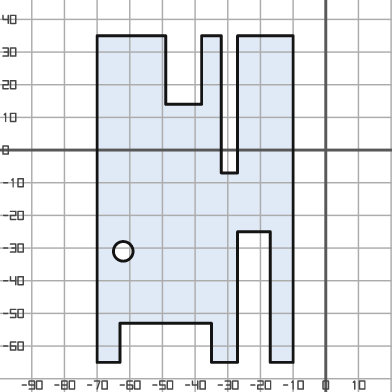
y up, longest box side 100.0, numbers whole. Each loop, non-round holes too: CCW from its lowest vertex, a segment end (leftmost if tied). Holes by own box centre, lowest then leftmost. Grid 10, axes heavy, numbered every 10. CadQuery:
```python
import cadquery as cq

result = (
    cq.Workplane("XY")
    .moveTo(-70.0, -65.0)
    .lineTo(-63.0, -65.0)
    .lineTo(-63.0, -53.0)
    .lineTo(-35.0, -53.0)
    .lineTo(-35.0, -65.0)
    .lineTo(-27.0, -65.0)
    .lineTo(-27.0, -25.0)
    .lineTo(-17.0, -25.0)
    .lineTo(-17.0, -65.0)
    .lineTo(-10.0, -65.0)
    .lineTo(-10.0, 35.0)
    .lineTo(-27.0, 35.0)
    .lineTo(-27.0, -7.0)
    .lineTo(-32.0, -7.0)
    .lineTo(-32.0, 35.0)
    .lineTo(-38.0, 35.0)
    .lineTo(-38.0, 14.0)
    .lineTo(-49.0, 14.0)
    .lineTo(-49.0, 35.0)
    .lineTo(-70.0, 35.0)
    .close()
    .moveTo(-62.0, -31.0)
    .circle(3.0)
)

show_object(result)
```